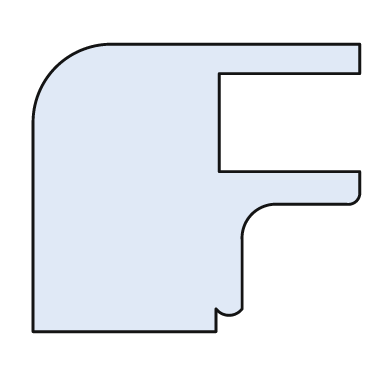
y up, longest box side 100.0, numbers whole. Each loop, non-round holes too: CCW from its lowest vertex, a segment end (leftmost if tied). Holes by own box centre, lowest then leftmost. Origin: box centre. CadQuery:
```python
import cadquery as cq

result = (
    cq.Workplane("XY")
    .moveTo(-50.0, -44.0)
    .lineTo(6.0, -44.0)
    .lineTo(6.0, -37.0)
    .threePointArc((10.0, -39.0), (14.0, -37.0))
    .lineTo(14.0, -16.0)
    .threePointArc((17.0, -8.0), (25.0, -5.0))
    .lineTo(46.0, -5.0)
    .threePointArc((49.0, -4.0), (50.0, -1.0))
    .lineTo(50.0, 5.0)
    .lineTo(7.0, 5.0)
    .lineTo(7.0, 35.0)
    .lineTo(50.0, 35.0)
    .lineTo(50.0, 44.0)
    .lineTo(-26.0, 44.0)
    .threePointArc((-43.0, 37.0), (-50.0, 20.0))
    .close()
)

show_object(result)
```